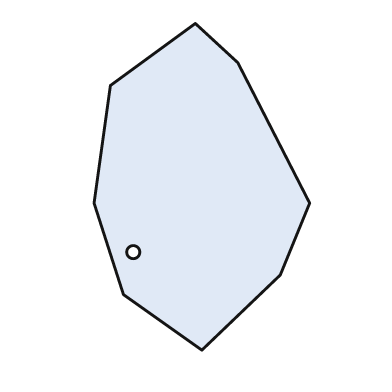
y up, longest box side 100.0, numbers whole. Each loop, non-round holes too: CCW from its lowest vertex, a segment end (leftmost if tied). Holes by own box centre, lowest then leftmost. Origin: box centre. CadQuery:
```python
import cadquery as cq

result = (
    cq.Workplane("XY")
    .moveTo(0.0, -50.0)
    .lineTo(24.0, -27.0)
    .lineTo(33.0, -5.0)
    .lineTo(11.0, 38.0)
    .lineTo(-2.0, 50.0)
    .lineTo(-28.0, 31.0)
    .lineTo(-33.0, -5.0)
    .lineTo(-24.0, -33.0)
    .close()
    .moveTo(-21.0, -20.0)
    .circle(2.0)
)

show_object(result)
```